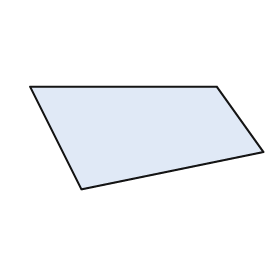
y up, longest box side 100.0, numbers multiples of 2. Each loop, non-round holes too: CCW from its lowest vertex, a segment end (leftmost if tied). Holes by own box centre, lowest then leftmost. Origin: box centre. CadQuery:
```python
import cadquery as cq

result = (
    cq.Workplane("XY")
    .moveTo(-28.0, -22.0)
    .lineTo(50.0, -6.0)
    .lineTo(30.0, 22.0)
    .lineTo(-50.0, 22.0)
    .close()
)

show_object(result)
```